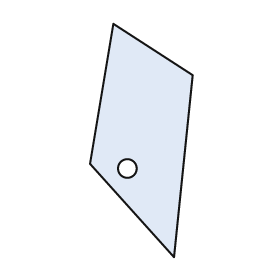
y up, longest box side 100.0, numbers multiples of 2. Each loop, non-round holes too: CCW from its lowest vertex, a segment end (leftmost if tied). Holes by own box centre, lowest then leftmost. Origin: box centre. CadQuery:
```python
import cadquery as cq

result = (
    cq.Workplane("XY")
    .moveTo(14.0, -50.0)
    .lineTo(22.0, 28.0)
    .lineTo(-12.0, 50.0)
    .lineTo(-22.0, -10.0)
    .close()
    .moveTo(-6.0, -12.0)
    .circle(4.0)
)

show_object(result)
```